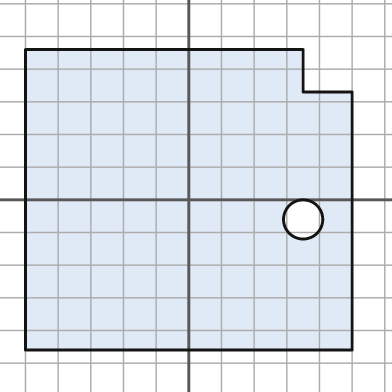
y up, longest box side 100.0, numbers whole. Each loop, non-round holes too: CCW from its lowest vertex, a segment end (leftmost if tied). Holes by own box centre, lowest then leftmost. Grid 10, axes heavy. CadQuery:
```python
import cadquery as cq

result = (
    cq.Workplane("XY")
    .moveTo(-50.0, -46.0)
    .lineTo(50.0, -46.0)
    .lineTo(50.0, 33.0)
    .lineTo(35.0, 33.0)
    .lineTo(35.0, 46.0)
    .lineTo(-50.0, 46.0)
    .close()
    .moveTo(35.0, -6.0)
    .circle(6.0)
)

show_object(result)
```